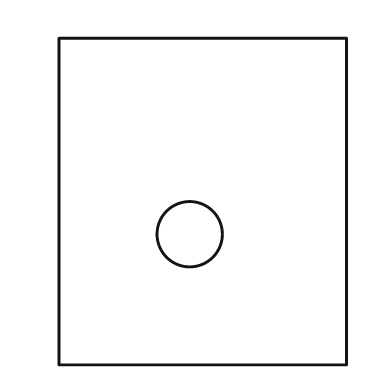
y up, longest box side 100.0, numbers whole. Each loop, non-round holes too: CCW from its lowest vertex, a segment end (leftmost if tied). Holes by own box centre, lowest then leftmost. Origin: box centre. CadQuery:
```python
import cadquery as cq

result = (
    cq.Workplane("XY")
    .moveTo(-44.0, -50.0)
    .lineTo(44.0, -50.0)
    .lineTo(44.0, 50.0)
    .lineTo(-44.0, 50.0)
    .close()
    .moveTo(-4.0, -10.0)
    .circle(10.0)
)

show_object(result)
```